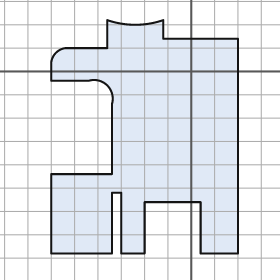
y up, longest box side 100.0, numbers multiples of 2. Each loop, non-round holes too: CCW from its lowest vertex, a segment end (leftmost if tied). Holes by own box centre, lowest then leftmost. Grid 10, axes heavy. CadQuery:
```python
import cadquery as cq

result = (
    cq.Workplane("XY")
    .moveTo(-60.0, -78.0)
    .lineTo(-34.0, -78.0)
    .lineTo(-34.0, -52.0)
    .lineTo(-30.0, -52.0)
    .lineTo(-30.0, -78.0)
    .lineTo(-20.0, -78.0)
    .lineTo(-20.0, -56.0)
    .lineTo(4.0, -56.0)
    .lineTo(4.0, -78.0)
    .lineTo(20.0, -78.0)
    .lineTo(20.0, 14.0)
    .lineTo(-12.0, 14.0)
    .lineTo(-12.0, 22.0)
    .threePointArc((-24.0, 20.0), (-36.0, 22.0))
    .lineTo(-36.0, 10.0)
    .lineTo(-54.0, 10.0)
    .threePointArc((-58.0, 8.0), (-60.0, 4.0))
    .lineTo(-60.0, -4.0)
    .lineTo(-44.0, -4.0)
    .threePointArc((-36.0, -6.0), (-34.0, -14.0))
    .lineTo(-34.0, -44.0)
    .lineTo(-60.0, -44.0)
    .close()
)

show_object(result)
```